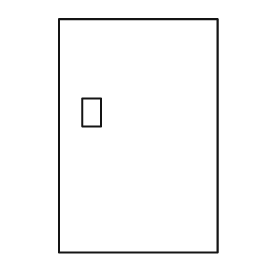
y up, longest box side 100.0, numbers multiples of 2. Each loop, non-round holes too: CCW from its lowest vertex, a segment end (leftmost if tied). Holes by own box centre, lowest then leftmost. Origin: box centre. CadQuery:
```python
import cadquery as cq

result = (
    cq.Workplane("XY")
    .moveTo(-34.0, -50.0)
    .lineTo(34.0, -50.0)
    .lineTo(34.0, 50.0)
    .lineTo(-34.0, 50.0)
    .close()
    .moveTo(-24.0, 4.0)
    .lineTo(-16.0, 4.0)
    .lineTo(-16.0, 16.0)
    .lineTo(-24.0, 16.0)
    .close()
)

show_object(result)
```